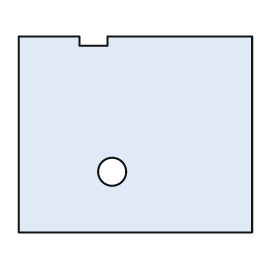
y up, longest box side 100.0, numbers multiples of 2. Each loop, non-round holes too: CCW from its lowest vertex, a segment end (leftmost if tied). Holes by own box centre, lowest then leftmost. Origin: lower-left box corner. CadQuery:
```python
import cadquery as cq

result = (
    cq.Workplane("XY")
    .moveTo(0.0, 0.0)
    .lineTo(100.0, 0.0)
    .lineTo(100.0, 84.0)
    .lineTo(38.0, 84.0)
    .lineTo(38.0, 80.0)
    .lineTo(26.0, 80.0)
    .lineTo(26.0, 84.0)
    .lineTo(0.0, 84.0)
    .close()
    .moveTo(40.0, 26.0)
    .circle(6.0)
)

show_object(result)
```